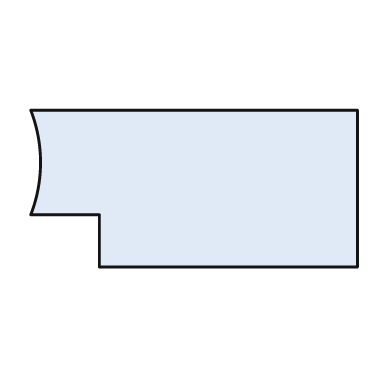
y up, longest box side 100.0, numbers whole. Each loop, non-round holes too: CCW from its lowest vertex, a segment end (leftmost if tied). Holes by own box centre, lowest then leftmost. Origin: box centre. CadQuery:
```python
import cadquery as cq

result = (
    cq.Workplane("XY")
    .moveTo(-29.0, -24.0)
    .lineTo(50.0, -24.0)
    .lineTo(50.0, 24.0)
    .lineTo(-50.0, 24.0)
    .threePointArc((-47.0, 8.0), (-50.0, -8.0))
    .lineTo(-29.0, -8.0)
    .close()
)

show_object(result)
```